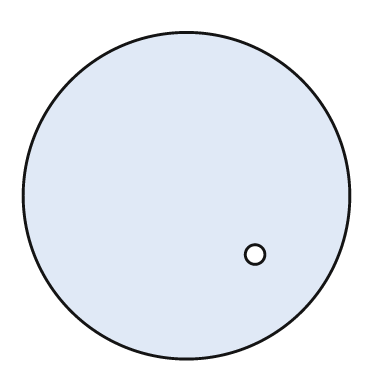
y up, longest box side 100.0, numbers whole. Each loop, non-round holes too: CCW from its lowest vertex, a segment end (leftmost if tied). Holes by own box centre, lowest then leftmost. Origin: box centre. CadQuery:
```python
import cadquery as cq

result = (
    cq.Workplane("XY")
    .moveTo(0.0, 0.0)
    .circle(50.0)
    .moveTo(21.0, -18.0)
    .circle(3.0)
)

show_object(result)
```